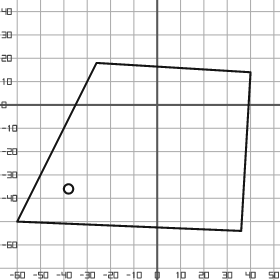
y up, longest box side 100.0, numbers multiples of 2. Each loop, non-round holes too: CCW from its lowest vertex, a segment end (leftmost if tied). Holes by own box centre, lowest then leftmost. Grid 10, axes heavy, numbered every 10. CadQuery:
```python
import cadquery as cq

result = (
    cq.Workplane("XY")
    .moveTo(36.0, -54.0)
    .lineTo(40.0, 14.0)
    .lineTo(-26.0, 18.0)
    .lineTo(-60.0, -50.0)
    .close()
    .moveTo(-38.0, -36.0)
    .circle(2.0)
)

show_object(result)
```